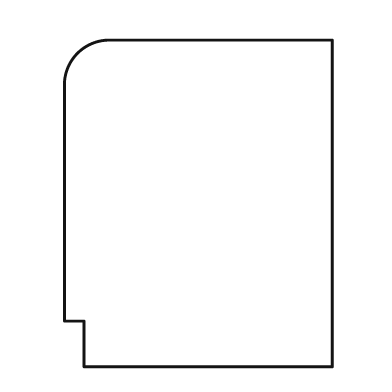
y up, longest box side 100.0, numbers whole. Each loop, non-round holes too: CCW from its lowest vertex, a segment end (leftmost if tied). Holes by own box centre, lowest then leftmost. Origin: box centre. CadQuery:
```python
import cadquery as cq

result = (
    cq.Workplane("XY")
    .moveTo(-35.0, -50.0)
    .lineTo(41.0, -50.0)
    .lineTo(41.0, 50.0)
    .lineTo(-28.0, 50.0)
    .threePointArc((-37.0, 46.0), (-41.0, 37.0))
    .lineTo(-41.0, -36.0)
    .lineTo(-35.0, -36.0)
    .close()
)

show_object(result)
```